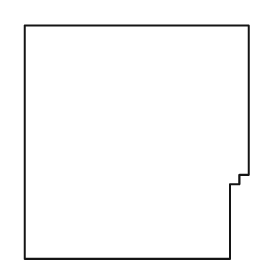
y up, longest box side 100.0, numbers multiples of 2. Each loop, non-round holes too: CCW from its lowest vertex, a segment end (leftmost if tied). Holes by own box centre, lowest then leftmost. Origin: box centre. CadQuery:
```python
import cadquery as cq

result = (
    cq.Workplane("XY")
    .moveTo(-48.0, -50.0)
    .lineTo(40.0, -50.0)
    .lineTo(40.0, -18.0)
    .lineTo(44.0, -18.0)
    .lineTo(44.0, -14.0)
    .lineTo(48.0, -14.0)
    .lineTo(48.0, 50.0)
    .lineTo(-48.0, 50.0)
    .close()
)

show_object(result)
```